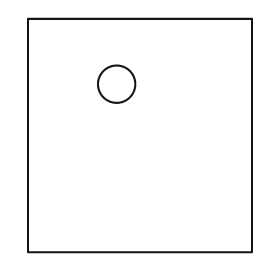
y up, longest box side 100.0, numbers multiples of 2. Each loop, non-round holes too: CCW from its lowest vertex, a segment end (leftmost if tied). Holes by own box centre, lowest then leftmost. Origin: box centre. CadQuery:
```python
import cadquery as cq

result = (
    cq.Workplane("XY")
    .moveTo(-48.0, -50.0)
    .lineTo(48.0, -50.0)
    .lineTo(48.0, 50.0)
    .lineTo(-48.0, 50.0)
    .close()
    .moveTo(-10.0, 22.0)
    .circle(8.0)
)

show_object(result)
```